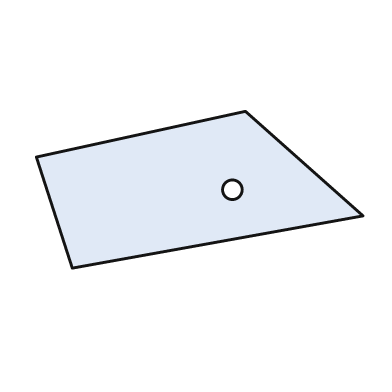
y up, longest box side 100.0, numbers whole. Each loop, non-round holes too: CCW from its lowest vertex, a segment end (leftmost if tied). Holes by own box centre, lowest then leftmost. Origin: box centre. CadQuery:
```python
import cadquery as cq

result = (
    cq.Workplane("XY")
    .moveTo(-39.0, -24.0)
    .lineTo(50.0, -8.0)
    .lineTo(14.0, 24.0)
    .lineTo(-50.0, 10.0)
    .close()
    .moveTo(10.0, 0.0)
    .circle(3.0)
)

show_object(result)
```